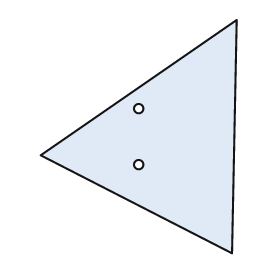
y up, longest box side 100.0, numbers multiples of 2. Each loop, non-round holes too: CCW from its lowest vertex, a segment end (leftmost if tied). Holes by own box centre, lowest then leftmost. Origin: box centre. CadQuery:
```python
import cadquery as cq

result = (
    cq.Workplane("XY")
    .moveTo(40.0, -50.0)
    .lineTo(42.0, 50.0)
    .lineTo(-42.0, -8.0)
    .close()
    .moveTo(0.0, -12.0)
    .circle(2.0)
    .moveTo(0.0, 12.0)
    .circle(2.0)
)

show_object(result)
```